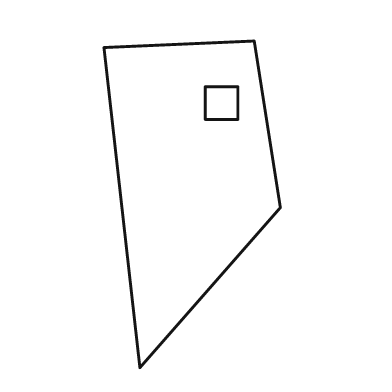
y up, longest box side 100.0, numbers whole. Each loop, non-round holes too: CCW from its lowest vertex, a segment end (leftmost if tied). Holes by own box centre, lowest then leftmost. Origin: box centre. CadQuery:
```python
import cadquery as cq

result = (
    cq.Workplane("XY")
    .moveTo(-16.0, -50.0)
    .lineTo(27.0, -1.0)
    .lineTo(19.0, 50.0)
    .lineTo(-27.0, 48.0)
    .close()
    .moveTo(4.0, 26.0)
    .lineTo(14.0, 26.0)
    .lineTo(14.0, 36.0)
    .lineTo(4.0, 36.0)
    .close()
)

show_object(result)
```